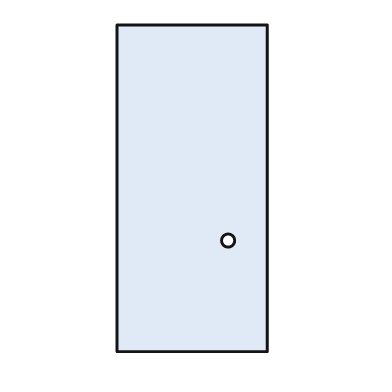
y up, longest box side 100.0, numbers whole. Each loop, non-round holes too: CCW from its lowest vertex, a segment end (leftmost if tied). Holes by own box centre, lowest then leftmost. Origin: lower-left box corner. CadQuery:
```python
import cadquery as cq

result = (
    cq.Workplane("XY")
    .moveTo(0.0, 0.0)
    .lineTo(46.0, 0.0)
    .lineTo(46.0, 100.0)
    .lineTo(0.0, 100.0)
    .close()
    .moveTo(34.0, 34.0)
    .circle(2.0)
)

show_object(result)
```